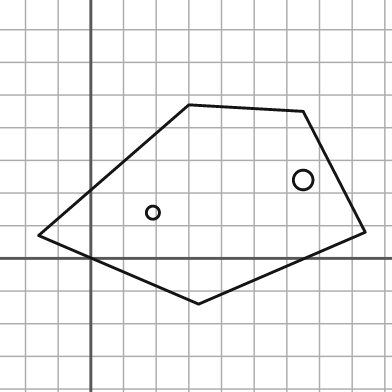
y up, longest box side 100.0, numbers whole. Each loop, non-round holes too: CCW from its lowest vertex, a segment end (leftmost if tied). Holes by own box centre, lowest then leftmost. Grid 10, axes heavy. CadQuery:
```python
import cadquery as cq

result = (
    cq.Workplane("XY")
    .moveTo(33.0, -14.0)
    .lineTo(84.0, 8.0)
    .lineTo(65.0, 45.0)
    .lineTo(30.0, 47.0)
    .lineTo(-16.0, 7.0)
    .close()
    .moveTo(19.0, 14.0)
    .circle(2.0)
    .moveTo(65.0, 24.0)
    .circle(3.0)
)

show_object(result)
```